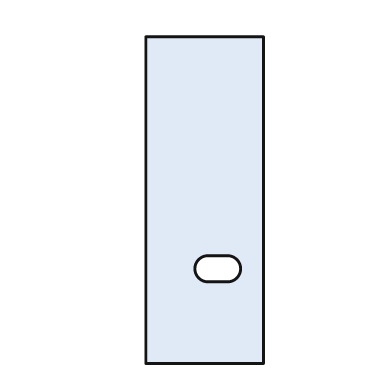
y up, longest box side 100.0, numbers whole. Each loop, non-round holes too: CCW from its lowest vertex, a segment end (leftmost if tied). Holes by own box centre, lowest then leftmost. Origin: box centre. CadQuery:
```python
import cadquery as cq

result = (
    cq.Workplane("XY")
    .moveTo(-18.0, -50.0)
    .lineTo(18.0, -50.0)
    .lineTo(18.0, 50.0)
    .lineTo(-18.0, 50.0)
    .close()
    .moveTo(1.0, -25.0)
    .lineTo(7.0, -25.0)
    .threePointArc((11.0, -21.0), (7.0, -17.0))
    .lineTo(1.0, -17.0)
    .threePointArc((-3.0, -21.0), (1.0, -25.0))
    .close()
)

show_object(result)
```